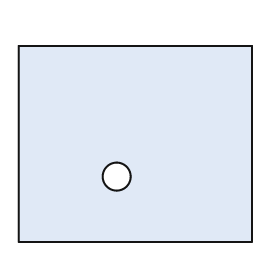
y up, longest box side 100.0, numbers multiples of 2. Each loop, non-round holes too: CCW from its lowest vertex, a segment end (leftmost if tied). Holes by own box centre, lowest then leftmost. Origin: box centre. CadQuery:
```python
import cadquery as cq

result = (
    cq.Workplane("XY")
    .moveTo(-50.0, -42.0)
    .lineTo(50.0, -42.0)
    .lineTo(50.0, 42.0)
    .lineTo(-50.0, 42.0)
    .close()
    .moveTo(-8.0, -14.0)
    .circle(6.0)
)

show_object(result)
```